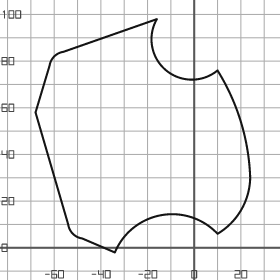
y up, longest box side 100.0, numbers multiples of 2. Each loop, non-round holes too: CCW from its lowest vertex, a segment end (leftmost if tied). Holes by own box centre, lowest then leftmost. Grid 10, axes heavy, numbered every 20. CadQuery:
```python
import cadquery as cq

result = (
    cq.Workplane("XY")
    .moveTo(-34.0, -2.0)
    .threePointArc((-14.0, 14.0), (10.0, 6.0))
    .threePointArc((20.0, 16.0), (24.0, 30.0))
    .threePointArc((20.0, 54.0), (10.0, 76.0))
    .threePointArc((-12.0, 76.0), (-16.0, 98.0))
    .lineTo(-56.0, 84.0)
    .threePointArc((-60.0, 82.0), (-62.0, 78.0))
    .lineTo(-68.0, 58.0)
    .lineTo(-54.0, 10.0)
    .threePointArc((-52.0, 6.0), (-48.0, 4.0))
    .close()
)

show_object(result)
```